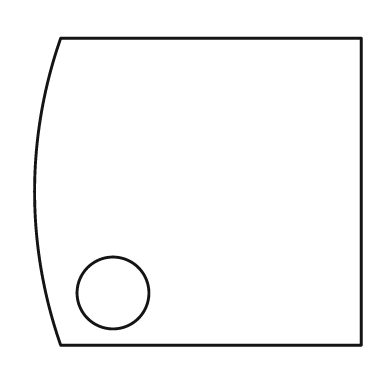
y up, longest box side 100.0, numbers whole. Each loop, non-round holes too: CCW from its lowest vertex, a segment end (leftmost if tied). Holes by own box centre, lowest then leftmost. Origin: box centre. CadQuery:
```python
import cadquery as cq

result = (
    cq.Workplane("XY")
    .moveTo(-42.0, -47.0)
    .lineTo(50.0, -47.0)
    .lineTo(50.0, 47.0)
    .lineTo(-42.0, 47.0)
    .threePointArc((-50.0, 0.0), (-42.0, -47.0))
    .close()
    .moveTo(-26.0, -31.0)
    .circle(11.0)
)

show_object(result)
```